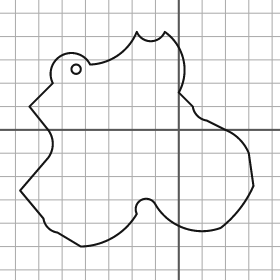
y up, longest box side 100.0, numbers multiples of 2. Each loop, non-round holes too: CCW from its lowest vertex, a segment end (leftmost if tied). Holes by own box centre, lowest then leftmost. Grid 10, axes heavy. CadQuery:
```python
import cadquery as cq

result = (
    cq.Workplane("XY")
    .moveTo(-42.0, -50.0)
    .threePointArc((-28.0, -46.0), (-18.0, -36.0))
    .threePointArc((-16.0, -30.0), (-10.0, -32.0))
    .threePointArc((2.0, -42.0), (18.0, -42.0))
    .threePointArc((26.0, -34.0), (32.0, -24.0))
    .lineTo(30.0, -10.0)
    .threePointArc((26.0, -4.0), (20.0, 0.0))
    .lineTo(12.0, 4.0)
    .threePointArc((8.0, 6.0), (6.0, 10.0))
    .lineTo(0.0, 16.0)
    .threePointArc((2.0, 30.0), (-6.0, 42.0))
    .threePointArc((-12.0, 38.0), (-18.0, 42.0))
    .threePointArc((-26.0, 32.0), (-38.0, 28.0))
    .threePointArc((-50.0, 32.0), (-54.0, 20.0))
    .lineTo(-64.0, 10.0)
    .lineTo(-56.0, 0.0)
    .threePointArc((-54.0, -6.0), (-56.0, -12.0))
    .lineTo(-68.0, -26.0)
    .lineTo(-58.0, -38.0)
    .threePointArc((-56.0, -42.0), (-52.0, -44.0))
    .close()
    .moveTo(-44.0, 26.0)
    .circle(2.0)
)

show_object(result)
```